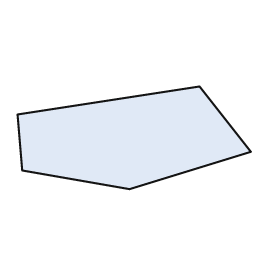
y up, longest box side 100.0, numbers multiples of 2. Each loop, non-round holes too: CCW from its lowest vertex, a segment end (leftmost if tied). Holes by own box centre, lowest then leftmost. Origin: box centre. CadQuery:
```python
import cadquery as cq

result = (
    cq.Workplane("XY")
    .moveTo(-2.0, -22.0)
    .lineTo(50.0, -6.0)
    .lineTo(28.0, 22.0)
    .lineTo(-50.0, 10.0)
    .lineTo(-48.0, -14.0)
    .close()
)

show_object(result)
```